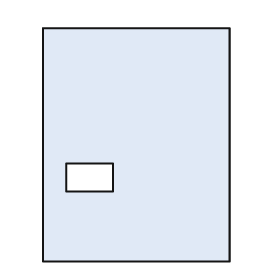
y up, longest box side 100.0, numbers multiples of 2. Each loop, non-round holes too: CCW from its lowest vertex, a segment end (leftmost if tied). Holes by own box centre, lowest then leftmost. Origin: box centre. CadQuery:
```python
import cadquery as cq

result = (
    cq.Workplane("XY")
    .moveTo(-40.0, -50.0)
    .lineTo(40.0, -50.0)
    .lineTo(40.0, 50.0)
    .lineTo(-40.0, 50.0)
    .close()
    .moveTo(-30.0, -20.0)
    .lineTo(-10.0, -20.0)
    .lineTo(-10.0, -8.0)
    .lineTo(-30.0, -8.0)
    .close()
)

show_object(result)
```